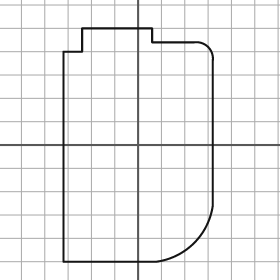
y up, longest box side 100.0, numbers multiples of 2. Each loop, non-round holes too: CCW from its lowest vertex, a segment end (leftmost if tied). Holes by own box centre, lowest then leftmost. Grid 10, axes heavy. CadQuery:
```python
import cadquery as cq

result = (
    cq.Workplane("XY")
    .moveTo(-32.0, -50.0)
    .lineTo(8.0, -50.0)
    .threePointArc((24.0, -42.0), (32.0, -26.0))
    .lineTo(32.0, 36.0)
    .threePointArc((30.0, 42.0), (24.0, 44.0))
    .lineTo(6.0, 44.0)
    .lineTo(6.0, 50.0)
    .lineTo(-24.0, 50.0)
    .lineTo(-24.0, 40.0)
    .lineTo(-32.0, 40.0)
    .close()
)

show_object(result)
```